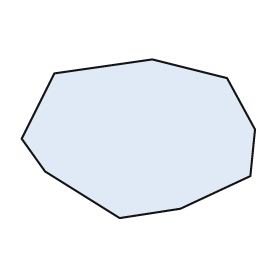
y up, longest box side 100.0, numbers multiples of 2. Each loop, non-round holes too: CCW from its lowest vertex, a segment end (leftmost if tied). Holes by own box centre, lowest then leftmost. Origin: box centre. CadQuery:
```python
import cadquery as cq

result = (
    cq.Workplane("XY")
    .moveTo(-8.0, -34.0)
    .lineTo(18.0, -30.0)
    .lineTo(48.0, -16.0)
    .lineTo(50.0, 4.0)
    .lineTo(38.0, 26.0)
    .lineTo(6.0, 34.0)
    .lineTo(-36.0, 28.0)
    .lineTo(-50.0, 0.0)
    .lineTo(-40.0, -14.0)
    .close()
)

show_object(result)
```